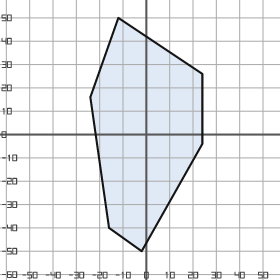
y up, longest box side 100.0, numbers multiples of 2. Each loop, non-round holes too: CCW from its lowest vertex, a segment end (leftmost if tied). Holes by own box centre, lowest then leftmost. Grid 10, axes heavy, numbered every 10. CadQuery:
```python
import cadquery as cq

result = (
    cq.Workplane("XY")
    .moveTo(-2.0, -50.0)
    .lineTo(24.0, -4.0)
    .lineTo(24.0, 26.0)
    .lineTo(-12.0, 50.0)
    .lineTo(-24.0, 16.0)
    .lineTo(-16.0, -40.0)
    .close()
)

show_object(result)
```